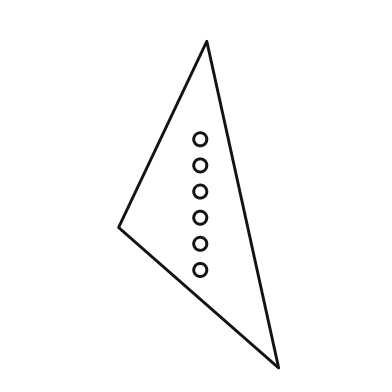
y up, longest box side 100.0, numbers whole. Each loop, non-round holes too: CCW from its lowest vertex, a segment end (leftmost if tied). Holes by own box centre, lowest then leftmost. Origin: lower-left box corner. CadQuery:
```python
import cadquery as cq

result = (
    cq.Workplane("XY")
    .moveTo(49.0, 0.0)
    .lineTo(27.0, 100.0)
    .lineTo(0.0, 43.0)
    .close()
    .moveTo(25.0, 30.0)
    .circle(2.0)
    .moveTo(25.0, 38.0)
    .circle(2.0)
    .moveTo(25.0, 46.0)
    .circle(2.0)
    .moveTo(25.0, 54.0)
    .circle(2.0)
    .moveTo(25.0, 62.0)
    .circle(2.0)
    .moveTo(25.0, 70.0)
    .circle(2.0)
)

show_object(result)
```